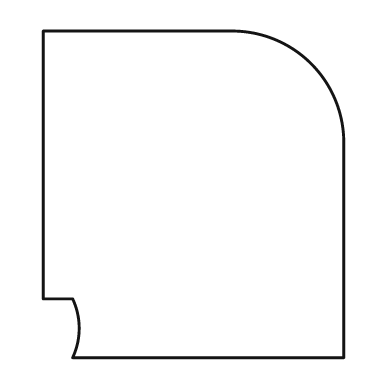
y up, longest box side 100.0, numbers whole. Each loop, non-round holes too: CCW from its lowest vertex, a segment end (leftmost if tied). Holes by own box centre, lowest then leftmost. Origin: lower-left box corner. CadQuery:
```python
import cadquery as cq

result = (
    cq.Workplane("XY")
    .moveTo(9.0, 0.0)
    .lineTo(92.0, 0.0)
    .lineTo(92.0, 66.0)
    .threePointArc((82.0, 90.0), (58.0, 100.0))
    .lineTo(0.0, 100.0)
    .lineTo(0.0, 18.0)
    .lineTo(9.0, 18.0)
    .threePointArc((11.0, 9.0), (9.0, 0.0))
    .close()
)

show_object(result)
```